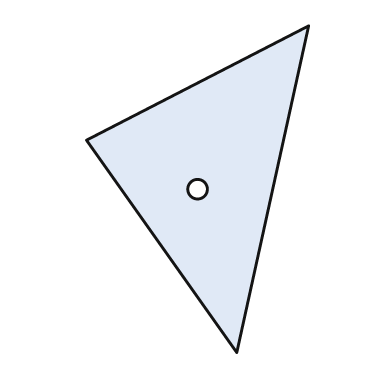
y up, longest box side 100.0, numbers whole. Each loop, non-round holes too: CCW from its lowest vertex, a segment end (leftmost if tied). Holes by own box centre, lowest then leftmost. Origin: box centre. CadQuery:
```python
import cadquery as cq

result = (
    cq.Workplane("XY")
    .moveTo(12.0, -50.0)
    .lineTo(34.0, 50.0)
    .lineTo(-34.0, 15.0)
    .close()
    .moveTo(0.0, 0.0)
    .circle(3.0)
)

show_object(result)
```